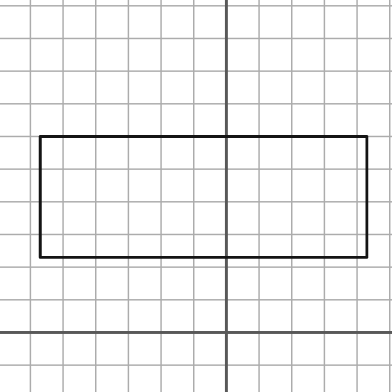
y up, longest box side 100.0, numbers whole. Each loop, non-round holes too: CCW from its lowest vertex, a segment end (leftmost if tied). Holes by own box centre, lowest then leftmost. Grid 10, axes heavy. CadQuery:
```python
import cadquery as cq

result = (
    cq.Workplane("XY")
    .moveTo(-57.0, 23.0)
    .lineTo(43.0, 23.0)
    .lineTo(43.0, 60.0)
    .lineTo(-57.0, 60.0)
    .close()
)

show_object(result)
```